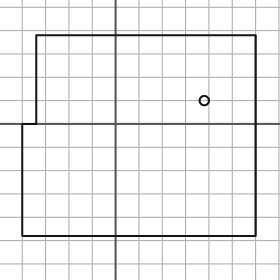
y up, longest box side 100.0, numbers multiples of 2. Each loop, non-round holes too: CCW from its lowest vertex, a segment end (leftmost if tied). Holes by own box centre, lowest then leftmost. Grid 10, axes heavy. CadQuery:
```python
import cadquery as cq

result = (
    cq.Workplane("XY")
    .moveTo(-40.0, -48.0)
    .lineTo(60.0, -48.0)
    .lineTo(60.0, 38.0)
    .lineTo(-34.0, 38.0)
    .lineTo(-34.0, 0.0)
    .lineTo(-40.0, 0.0)
    .close()
    .moveTo(38.0, 10.0)
    .circle(2.0)
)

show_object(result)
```